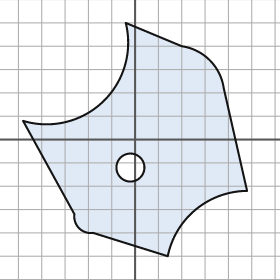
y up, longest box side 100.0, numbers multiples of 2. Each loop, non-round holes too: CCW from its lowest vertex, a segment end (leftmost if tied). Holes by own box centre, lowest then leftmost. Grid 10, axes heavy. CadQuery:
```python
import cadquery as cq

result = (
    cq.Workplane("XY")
    .moveTo(14.0, -50.0)
    .threePointArc((26.0, -30.0), (48.0, -22.0))
    .lineTo(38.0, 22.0)
    .threePointArc((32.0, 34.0), (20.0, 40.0))
    .lineTo(-4.0, 50.0)
    .threePointArc((-14.0, 16.0), (-48.0, 8.0))
    .lineTo(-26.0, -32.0)
    .threePointArc((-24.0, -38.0), (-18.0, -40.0))
    .close()
    .moveTo(-2.0, -12.0)
    .circle(6.0)
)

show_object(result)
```